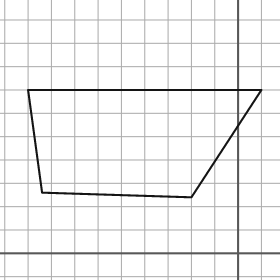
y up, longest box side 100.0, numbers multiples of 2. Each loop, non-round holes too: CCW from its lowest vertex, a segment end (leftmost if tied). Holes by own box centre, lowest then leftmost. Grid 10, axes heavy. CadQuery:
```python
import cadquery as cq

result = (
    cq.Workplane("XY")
    .moveTo(-20.0, 24.0)
    .lineTo(10.0, 70.0)
    .lineTo(-90.0, 70.0)
    .lineTo(-84.0, 26.0)
    .close()
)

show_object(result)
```